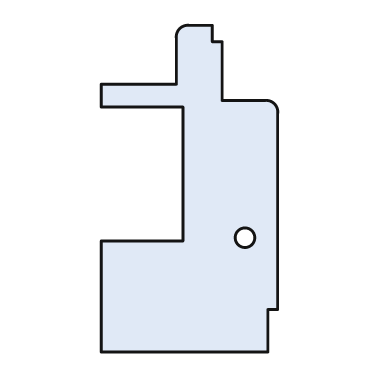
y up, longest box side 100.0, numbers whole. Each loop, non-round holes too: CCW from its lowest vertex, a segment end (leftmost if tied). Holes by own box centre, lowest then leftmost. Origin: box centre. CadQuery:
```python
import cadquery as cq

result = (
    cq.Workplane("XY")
    .moveTo(-27.0, -50.0)
    .lineTo(24.0, -50.0)
    .lineTo(24.0, -37.0)
    .lineTo(27.0, -37.0)
    .lineTo(27.0, 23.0)
    .threePointArc((26.0, 26.0), (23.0, 27.0))
    .lineTo(10.0, 27.0)
    .lineTo(10.0, 45.0)
    .lineTo(7.0, 45.0)
    .lineTo(7.0, 50.0)
    .lineTo(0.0, 50.0)
    .threePointArc((-3.0, 49.0), (-4.0, 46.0))
    .lineTo(-4.0, 32.0)
    .lineTo(-27.0, 32.0)
    .lineTo(-27.0, 25.0)
    .lineTo(-2.0, 25.0)
    .lineTo(-2.0, -16.0)
    .lineTo(-27.0, -16.0)
    .close()
    .moveTo(17.0, -15.0)
    .circle(3.0)
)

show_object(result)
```